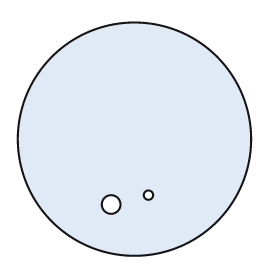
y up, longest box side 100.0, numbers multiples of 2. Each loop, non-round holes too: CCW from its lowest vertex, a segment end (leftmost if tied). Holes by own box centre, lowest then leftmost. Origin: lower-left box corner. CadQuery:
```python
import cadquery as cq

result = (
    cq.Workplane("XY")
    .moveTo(50.0, 50.0)
    .circle(50.0)
    .moveTo(40.0, 22.0)
    .circle(4.0)
    .moveTo(56.0, 26.0)
    .circle(2.0)
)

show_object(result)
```